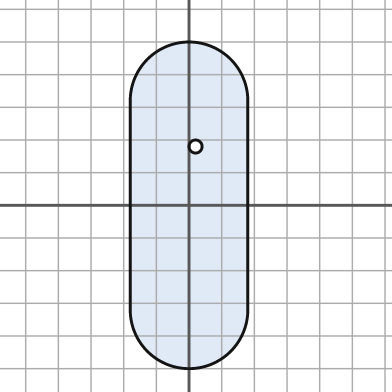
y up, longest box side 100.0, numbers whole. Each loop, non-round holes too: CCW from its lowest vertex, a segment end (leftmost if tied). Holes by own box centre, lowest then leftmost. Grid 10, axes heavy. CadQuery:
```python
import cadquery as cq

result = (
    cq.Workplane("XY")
    .moveTo(-18.0, -32.0)
    .threePointArc((0.0, -50.0), (18.0, -32.0))
    .lineTo(18.0, 32.0)
    .threePointArc((0.0, 50.0), (-18.0, 32.0))
    .close()
    .moveTo(2.0, 18.0)
    .circle(2.0)
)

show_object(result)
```